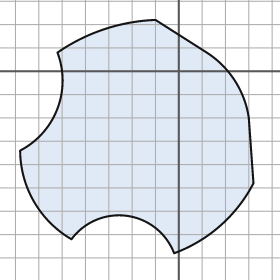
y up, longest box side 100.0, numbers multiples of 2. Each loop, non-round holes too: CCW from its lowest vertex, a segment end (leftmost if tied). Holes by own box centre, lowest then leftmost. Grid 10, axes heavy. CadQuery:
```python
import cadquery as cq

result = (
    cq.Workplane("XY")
    .moveTo(-2.0, -78.0)
    .threePointArc((18.0, -66.0), (32.0, -48.0))
    .lineTo(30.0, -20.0)
    .threePointArc((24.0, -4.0), (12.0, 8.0))
    .lineTo(-10.0, 22.0)
    .threePointArc((-32.0, 18.0), (-52.0, 8.0))
    .threePointArc((-52.0, -16.0), (-68.0, -34.0))
    .threePointArc((-62.0, -56.0), (-46.0, -72.0))
    .threePointArc((-22.0, -62.0), (-2.0, -78.0))
    .close()
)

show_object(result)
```